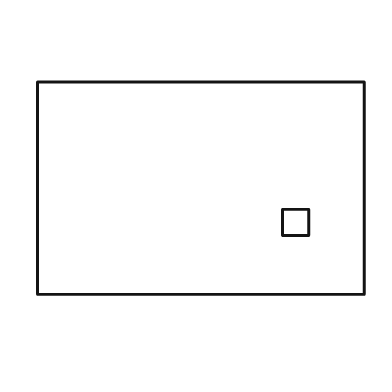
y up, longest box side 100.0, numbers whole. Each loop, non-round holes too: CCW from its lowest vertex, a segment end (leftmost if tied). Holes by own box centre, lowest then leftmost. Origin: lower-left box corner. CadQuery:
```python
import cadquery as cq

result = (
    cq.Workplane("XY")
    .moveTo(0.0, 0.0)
    .lineTo(100.0, 0.0)
    .lineTo(100.0, 65.0)
    .lineTo(0.0, 65.0)
    .close()
    .moveTo(75.0, 18.0)
    .lineTo(83.0, 18.0)
    .lineTo(83.0, 26.0)
    .lineTo(75.0, 26.0)
    .close()
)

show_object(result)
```